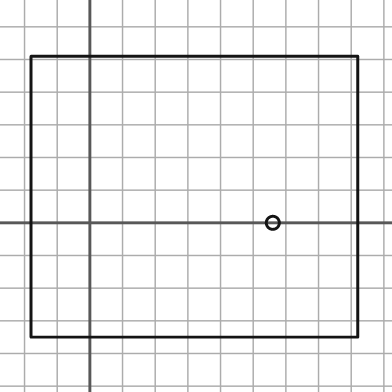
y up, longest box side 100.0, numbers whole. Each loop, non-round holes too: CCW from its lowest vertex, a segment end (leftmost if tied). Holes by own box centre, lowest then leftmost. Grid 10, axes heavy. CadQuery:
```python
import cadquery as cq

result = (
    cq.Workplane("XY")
    .moveTo(-18.0, -35.0)
    .lineTo(82.0, -35.0)
    .lineTo(82.0, 51.0)
    .lineTo(-18.0, 51.0)
    .close()
    .moveTo(56.0, 0.0)
    .circle(2.0)
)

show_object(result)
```